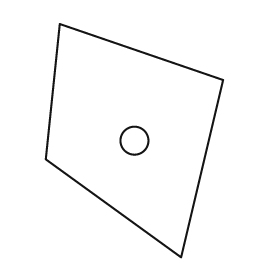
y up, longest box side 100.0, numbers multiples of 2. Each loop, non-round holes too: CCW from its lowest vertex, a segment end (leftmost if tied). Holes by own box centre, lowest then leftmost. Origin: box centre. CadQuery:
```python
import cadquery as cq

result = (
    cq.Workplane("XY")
    .moveTo(20.0, -50.0)
    .lineTo(38.0, 26.0)
    .lineTo(-32.0, 50.0)
    .lineTo(-38.0, -8.0)
    .close()
    .moveTo(0.0, 0.0)
    .circle(6.0)
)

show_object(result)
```